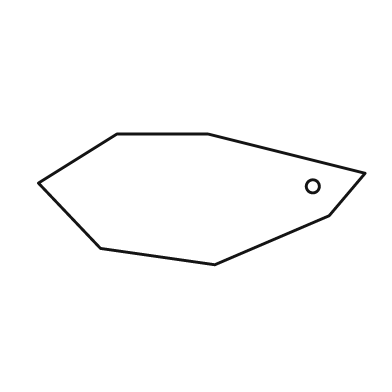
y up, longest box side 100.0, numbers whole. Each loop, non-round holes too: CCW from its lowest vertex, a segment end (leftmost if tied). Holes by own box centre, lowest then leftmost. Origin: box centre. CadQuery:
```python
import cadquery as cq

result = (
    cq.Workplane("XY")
    .moveTo(4.0, -20.0)
    .lineTo(39.0, -5.0)
    .lineTo(50.0, 8.0)
    .lineTo(2.0, 20.0)
    .lineTo(-26.0, 20.0)
    .lineTo(-50.0, 5.0)
    .lineTo(-31.0, -15.0)
    .close()
    .moveTo(34.0, 4.0)
    .circle(2.0)
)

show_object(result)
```